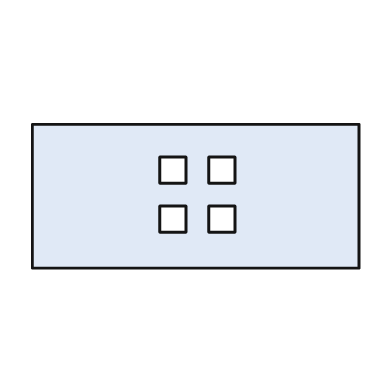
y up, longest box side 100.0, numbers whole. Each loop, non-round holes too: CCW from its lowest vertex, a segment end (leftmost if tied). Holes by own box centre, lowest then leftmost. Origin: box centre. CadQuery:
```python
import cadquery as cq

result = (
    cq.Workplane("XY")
    .moveTo(-50.0, -22.0)
    .lineTo(50.0, -22.0)
    .lineTo(50.0, 22.0)
    .lineTo(-50.0, 22.0)
    .close()
    .moveTo(-11.0, -11.0)
    .lineTo(-3.0, -11.0)
    .lineTo(-3.0, -3.0)
    .lineTo(-11.0, -3.0)
    .close()
    .moveTo(4.0, -11.0)
    .lineTo(12.0, -11.0)
    .lineTo(12.0, -3.0)
    .lineTo(4.0, -3.0)
    .close()
    .moveTo(-11.0, 4.0)
    .lineTo(-3.0, 4.0)
    .lineTo(-3.0, 12.0)
    .lineTo(-11.0, 12.0)
    .close()
    .moveTo(4.0, 4.0)
    .lineTo(12.0, 4.0)
    .lineTo(12.0, 12.0)
    .lineTo(4.0, 12.0)
    .close()
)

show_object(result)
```